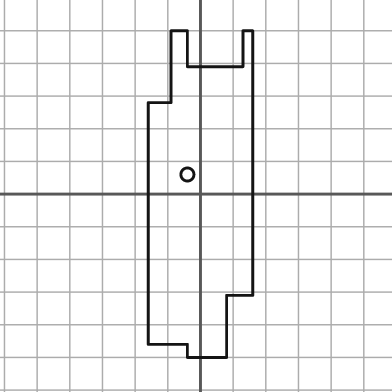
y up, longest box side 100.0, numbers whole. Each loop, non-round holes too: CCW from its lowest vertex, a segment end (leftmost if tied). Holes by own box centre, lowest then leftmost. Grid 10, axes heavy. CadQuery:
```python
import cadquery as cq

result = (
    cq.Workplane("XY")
    .moveTo(-4.0, -50.0)
    .lineTo(8.0, -50.0)
    .lineTo(8.0, -31.0)
    .lineTo(16.0, -31.0)
    .lineTo(16.0, 50.0)
    .lineTo(13.0, 50.0)
    .lineTo(13.0, 39.0)
    .lineTo(-4.0, 39.0)
    .lineTo(-4.0, 50.0)
    .lineTo(-9.0, 50.0)
    .lineTo(-9.0, 28.0)
    .lineTo(-16.0, 28.0)
    .lineTo(-16.0, -46.0)
    .lineTo(-4.0, -46.0)
    .close()
    .moveTo(-4.0, 6.0)
    .circle(2.0)
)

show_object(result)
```